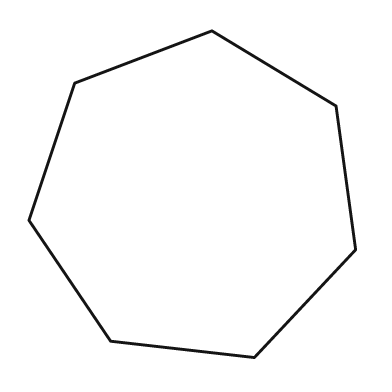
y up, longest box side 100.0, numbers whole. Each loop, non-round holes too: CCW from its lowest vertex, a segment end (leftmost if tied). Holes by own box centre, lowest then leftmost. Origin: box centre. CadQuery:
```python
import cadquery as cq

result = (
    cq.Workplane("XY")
    .moveTo(19.0, -50.0)
    .lineTo(50.0, -17.0)
    .lineTo(44.0, 27.0)
    .lineTo(6.0, 50.0)
    .lineTo(-36.0, 34.0)
    .lineTo(-50.0, -8.0)
    .lineTo(-25.0, -45.0)
    .close()
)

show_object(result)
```